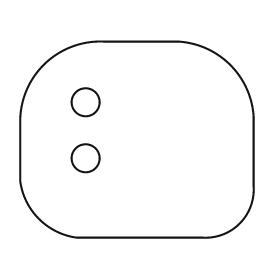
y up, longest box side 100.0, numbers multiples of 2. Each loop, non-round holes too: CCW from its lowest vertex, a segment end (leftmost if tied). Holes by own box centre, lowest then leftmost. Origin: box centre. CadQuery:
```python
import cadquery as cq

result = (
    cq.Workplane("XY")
    .moveTo(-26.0, -42.0)
    .lineTo(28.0, -42.0)
    .threePointArc((44.0, -36.0), (50.0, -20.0))
    .lineTo(50.0, 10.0)
    .threePointArc((40.0, 32.0), (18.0, 42.0))
    .lineTo(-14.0, 42.0)
    .threePointArc((-40.0, 32.0), (-50.0, 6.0))
    .lineTo(-50.0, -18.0)
    .threePointArc((-42.0, -34.0), (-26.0, -42.0))
    .close()
    .moveTo(-22.0, -8.0)
    .circle(6.0)
    .moveTo(-22.0, 16.0)
    .circle(6.0)
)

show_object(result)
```